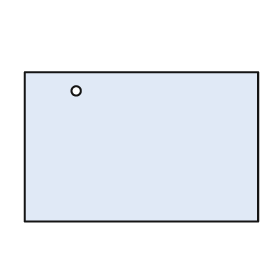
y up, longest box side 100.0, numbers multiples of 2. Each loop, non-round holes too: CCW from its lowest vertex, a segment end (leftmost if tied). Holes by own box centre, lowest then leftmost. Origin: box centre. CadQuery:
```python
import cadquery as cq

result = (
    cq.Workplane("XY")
    .moveTo(-50.0, -32.0)
    .lineTo(50.0, -32.0)
    .lineTo(50.0, 32.0)
    .lineTo(-50.0, 32.0)
    .close()
    .moveTo(-28.0, 24.0)
    .circle(2.0)
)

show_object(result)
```